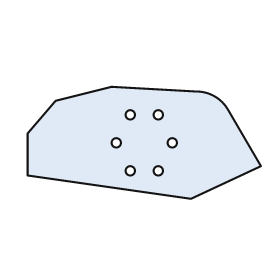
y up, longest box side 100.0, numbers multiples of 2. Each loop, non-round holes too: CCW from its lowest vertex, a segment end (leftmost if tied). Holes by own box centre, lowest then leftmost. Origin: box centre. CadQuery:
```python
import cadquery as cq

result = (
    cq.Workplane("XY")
    .moveTo(20.0, -24.0)
    .lineTo(50.0, -10.0)
    .lineTo(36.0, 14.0)
    .threePointArc((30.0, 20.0), (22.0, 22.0))
    .lineTo(-14.0, 24.0)
    .lineTo(-38.0, 18.0)
    .lineTo(-50.0, 4.0)
    .lineTo(-50.0, -14.0)
    .close()
    .moveTo(-6.0, -12.0)
    .circle(2.0)
    .moveTo(6.0, -12.0)
    .circle(2.0)
    .moveTo(-12.0, 0.0)
    .circle(2.0)
    .moveTo(12.0, 0.0)
    .circle(2.0)
    .moveTo(-6.0, 12.0)
    .circle(2.0)
    .moveTo(6.0, 12.0)
    .circle(2.0)
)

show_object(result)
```